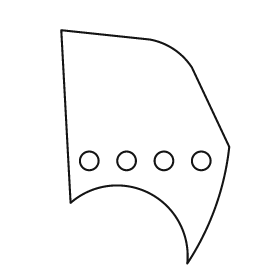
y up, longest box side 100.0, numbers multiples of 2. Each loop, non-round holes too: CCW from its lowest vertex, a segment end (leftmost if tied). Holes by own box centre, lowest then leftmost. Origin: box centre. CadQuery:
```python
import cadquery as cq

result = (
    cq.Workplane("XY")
    .moveTo(18.0, -50.0)
    .threePointArc((30.0, -26.0), (36.0, 0.0))
    .lineTo(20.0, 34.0)
    .threePointArc((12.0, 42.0), (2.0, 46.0))
    .lineTo(-36.0, 50.0)
    .lineTo(-32.0, -24.0)
    .threePointArc((2.0, -20.0), (18.0, -50.0))
    .close()
    .moveTo(-24.0, -6.0)
    .circle(4.0)
    .moveTo(-8.0, -6.0)
    .circle(4.0)
    .moveTo(8.0, -6.0)
    .circle(4.0)
    .moveTo(24.0, -6.0)
    .circle(4.0)
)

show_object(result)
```